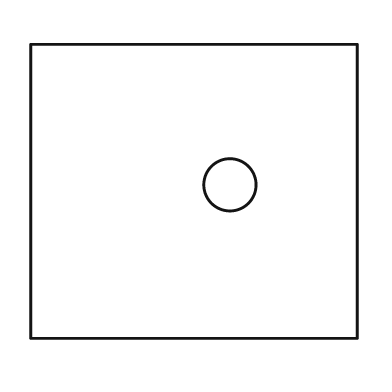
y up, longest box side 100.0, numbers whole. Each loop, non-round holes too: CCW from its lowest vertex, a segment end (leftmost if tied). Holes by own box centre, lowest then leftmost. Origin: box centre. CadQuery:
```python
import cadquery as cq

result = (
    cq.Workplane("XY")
    .moveTo(-50.0, -45.0)
    .lineTo(50.0, -45.0)
    .lineTo(50.0, 45.0)
    .lineTo(-50.0, 45.0)
    .close()
    .moveTo(11.0, 2.0)
    .circle(8.0)
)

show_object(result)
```